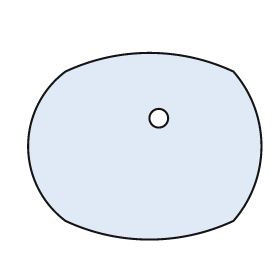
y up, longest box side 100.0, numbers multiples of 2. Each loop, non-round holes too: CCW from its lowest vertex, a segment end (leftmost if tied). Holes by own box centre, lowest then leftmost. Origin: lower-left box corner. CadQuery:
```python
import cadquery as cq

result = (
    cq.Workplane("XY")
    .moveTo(16.0, 8.0)
    .threePointArc((52.0, 0.0), (88.0, 8.0))
    .threePointArc((100.0, 40.0), (88.0, 72.0))
    .threePointArc((52.0, 80.0), (16.0, 72.0))
    .threePointArc((0.0, 40.0), (16.0, 8.0))
    .close()
    .moveTo(56.0, 52.0)
    .circle(4.0)
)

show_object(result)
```